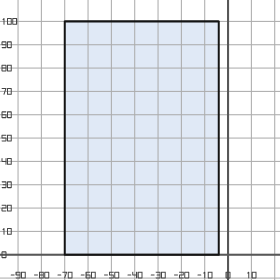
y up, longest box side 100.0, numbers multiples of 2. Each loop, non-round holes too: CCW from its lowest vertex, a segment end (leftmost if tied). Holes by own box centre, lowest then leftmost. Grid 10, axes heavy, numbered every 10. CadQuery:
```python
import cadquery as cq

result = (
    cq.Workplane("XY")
    .moveTo(-70.0, 0.0)
    .lineTo(-4.0, 0.0)
    .lineTo(-4.0, 100.0)
    .lineTo(-70.0, 100.0)
    .close()
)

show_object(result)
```